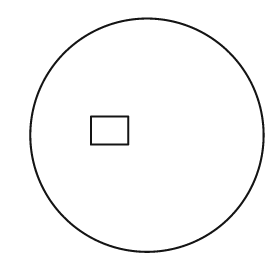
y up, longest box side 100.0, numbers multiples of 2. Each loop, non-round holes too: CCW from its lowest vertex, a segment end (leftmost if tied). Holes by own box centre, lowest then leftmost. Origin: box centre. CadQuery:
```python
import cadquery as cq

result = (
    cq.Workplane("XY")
    .moveTo(0.0, 0.0)
    .circle(50.0)
    .moveTo(-24.0, -4.0)
    .lineTo(-8.0, -4.0)
    .lineTo(-8.0, 8.0)
    .lineTo(-24.0, 8.0)
    .close()
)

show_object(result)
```